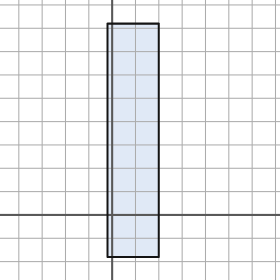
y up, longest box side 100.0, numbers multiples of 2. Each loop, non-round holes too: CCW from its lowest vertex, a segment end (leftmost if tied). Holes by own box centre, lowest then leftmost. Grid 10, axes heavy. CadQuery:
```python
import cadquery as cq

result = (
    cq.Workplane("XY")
    .moveTo(-2.0, -18.0)
    .lineTo(20.0, -18.0)
    .lineTo(20.0, 82.0)
    .lineTo(-2.0, 82.0)
    .close()
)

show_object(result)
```